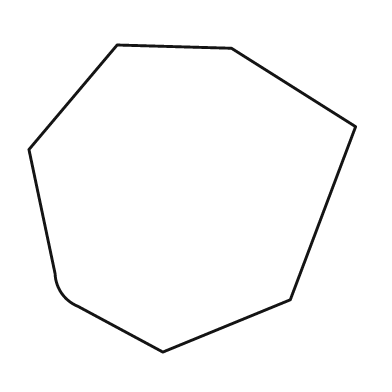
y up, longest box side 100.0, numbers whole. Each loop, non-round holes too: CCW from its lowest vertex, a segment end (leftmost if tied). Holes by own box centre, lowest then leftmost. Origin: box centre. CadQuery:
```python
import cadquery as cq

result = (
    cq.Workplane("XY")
    .moveTo(-9.0, -47.0)
    .lineTo(30.0, -31.0)
    .lineTo(50.0, 22.0)
    .lineTo(12.0, 46.0)
    .lineTo(-23.0, 47.0)
    .lineTo(-50.0, 15.0)
    .lineTo(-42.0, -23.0)
    .threePointArc((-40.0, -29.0), (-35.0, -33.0))
    .close()
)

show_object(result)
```